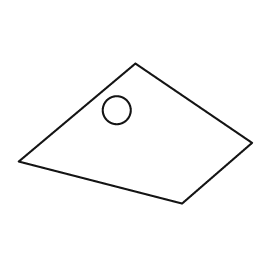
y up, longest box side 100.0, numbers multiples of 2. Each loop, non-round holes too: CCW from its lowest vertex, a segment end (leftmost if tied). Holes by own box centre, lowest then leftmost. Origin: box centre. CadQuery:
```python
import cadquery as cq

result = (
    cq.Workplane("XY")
    .moveTo(20.0, -30.0)
    .lineTo(50.0, -4.0)
    .lineTo(0.0, 30.0)
    .lineTo(-50.0, -12.0)
    .close()
    .moveTo(-8.0, 10.0)
    .circle(6.0)
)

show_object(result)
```